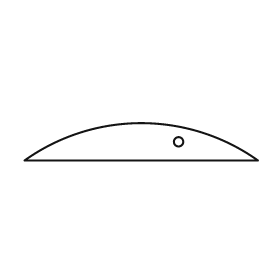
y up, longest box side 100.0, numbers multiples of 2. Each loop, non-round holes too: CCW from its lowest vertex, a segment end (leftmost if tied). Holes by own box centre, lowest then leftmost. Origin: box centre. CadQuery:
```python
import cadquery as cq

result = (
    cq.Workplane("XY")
    .moveTo(-50.0, -8.0)
    .lineTo(50.0, -8.0)
    .threePointArc((0.0, 8.0), (-50.0, -8.0))
    .close()
    .moveTo(16.0, 0.0)
    .circle(2.0)
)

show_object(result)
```